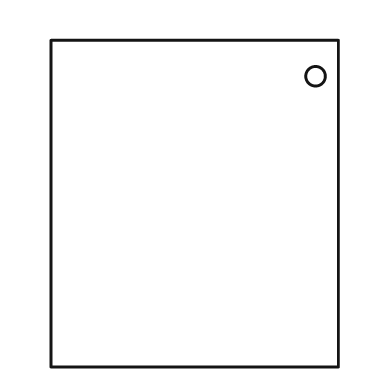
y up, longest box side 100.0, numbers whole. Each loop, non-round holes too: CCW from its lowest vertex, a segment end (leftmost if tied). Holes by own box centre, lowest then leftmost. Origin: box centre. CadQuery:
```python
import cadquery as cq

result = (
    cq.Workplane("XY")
    .moveTo(-44.0, -50.0)
    .lineTo(44.0, -50.0)
    .lineTo(44.0, 50.0)
    .lineTo(-44.0, 50.0)
    .close()
    .moveTo(37.0, 39.0)
    .circle(3.0)
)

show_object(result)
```